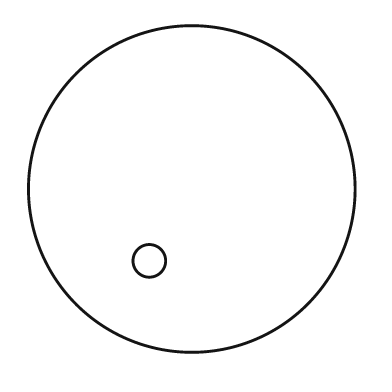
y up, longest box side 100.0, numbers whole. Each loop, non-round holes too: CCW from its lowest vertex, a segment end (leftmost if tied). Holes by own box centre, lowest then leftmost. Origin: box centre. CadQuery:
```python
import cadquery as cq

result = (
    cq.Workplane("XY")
    .moveTo(0.0, 0.0)
    .circle(50.0)
    .moveTo(-13.0, -22.0)
    .circle(5.0)
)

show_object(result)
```